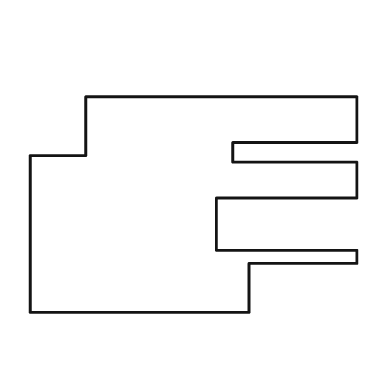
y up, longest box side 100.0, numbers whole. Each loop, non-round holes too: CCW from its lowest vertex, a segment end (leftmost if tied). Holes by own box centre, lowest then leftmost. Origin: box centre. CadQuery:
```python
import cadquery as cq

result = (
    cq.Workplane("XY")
    .moveTo(-50.0, -33.0)
    .lineTo(17.0, -33.0)
    .lineTo(17.0, -18.0)
    .lineTo(50.0, -18.0)
    .lineTo(50.0, -14.0)
    .lineTo(7.0, -14.0)
    .lineTo(7.0, 2.0)
    .lineTo(50.0, 2.0)
    .lineTo(50.0, 13.0)
    .lineTo(12.0, 13.0)
    .lineTo(12.0, 19.0)
    .lineTo(50.0, 19.0)
    .lineTo(50.0, 33.0)
    .lineTo(-33.0, 33.0)
    .lineTo(-33.0, 15.0)
    .lineTo(-50.0, 15.0)
    .close()
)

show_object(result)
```